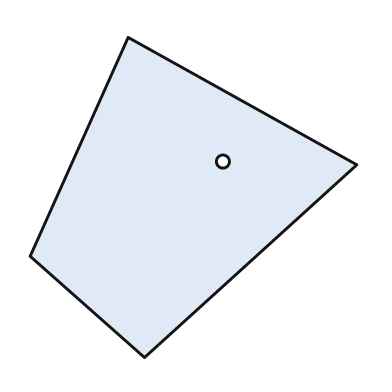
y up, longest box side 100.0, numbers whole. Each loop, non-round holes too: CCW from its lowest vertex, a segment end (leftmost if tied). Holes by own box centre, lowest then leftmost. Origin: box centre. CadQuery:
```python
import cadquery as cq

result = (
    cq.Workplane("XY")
    .moveTo(-15.0, -49.0)
    .lineTo(50.0, 10.0)
    .lineTo(-20.0, 49.0)
    .lineTo(-50.0, -18.0)
    .close()
    .moveTo(9.0, 11.0)
    .circle(2.0)
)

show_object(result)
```